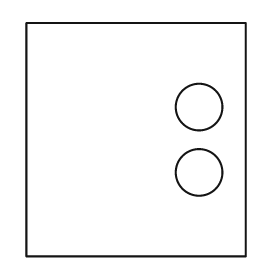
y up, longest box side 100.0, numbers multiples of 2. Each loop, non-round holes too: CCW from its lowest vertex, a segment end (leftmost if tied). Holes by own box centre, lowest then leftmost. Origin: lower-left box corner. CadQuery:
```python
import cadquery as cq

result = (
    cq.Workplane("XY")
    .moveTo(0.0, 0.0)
    .lineTo(94.0, 0.0)
    .lineTo(94.0, 100.0)
    .lineTo(0.0, 100.0)
    .close()
    .moveTo(74.0, 36.0)
    .circle(10.0)
    .moveTo(74.0, 64.0)
    .circle(10.0)
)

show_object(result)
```